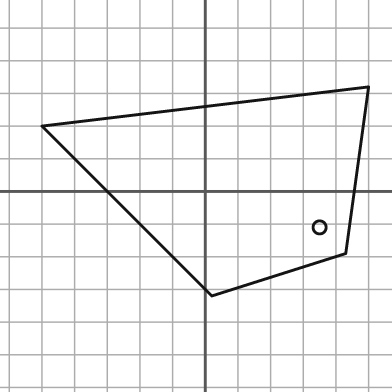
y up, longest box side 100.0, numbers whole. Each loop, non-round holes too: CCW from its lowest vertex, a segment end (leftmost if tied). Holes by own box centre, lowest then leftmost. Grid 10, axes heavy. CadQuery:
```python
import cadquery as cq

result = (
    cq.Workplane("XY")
    .moveTo(2.0, -32.0)
    .lineTo(43.0, -19.0)
    .lineTo(50.0, 32.0)
    .lineTo(-50.0, 20.0)
    .close()
    .moveTo(35.0, -11.0)
    .circle(2.0)
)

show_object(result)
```